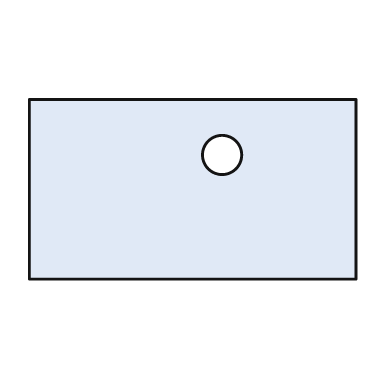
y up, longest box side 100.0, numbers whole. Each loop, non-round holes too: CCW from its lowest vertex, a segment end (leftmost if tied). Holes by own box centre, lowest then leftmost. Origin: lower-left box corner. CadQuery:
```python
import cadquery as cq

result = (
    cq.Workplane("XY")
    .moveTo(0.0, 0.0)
    .lineTo(100.0, 0.0)
    .lineTo(100.0, 55.0)
    .lineTo(0.0, 55.0)
    .close()
    .moveTo(59.0, 38.0)
    .circle(6.0)
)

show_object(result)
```